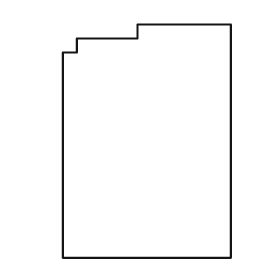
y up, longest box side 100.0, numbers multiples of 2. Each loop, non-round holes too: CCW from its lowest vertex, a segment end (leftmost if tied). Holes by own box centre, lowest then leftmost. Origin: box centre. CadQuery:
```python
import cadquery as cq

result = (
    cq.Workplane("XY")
    .moveTo(-36.0, -50.0)
    .lineTo(36.0, -50.0)
    .lineTo(36.0, 50.0)
    .lineTo(-4.0, 50.0)
    .lineTo(-4.0, 44.0)
    .lineTo(-30.0, 44.0)
    .lineTo(-30.0, 38.0)
    .lineTo(-36.0, 38.0)
    .close()
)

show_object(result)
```